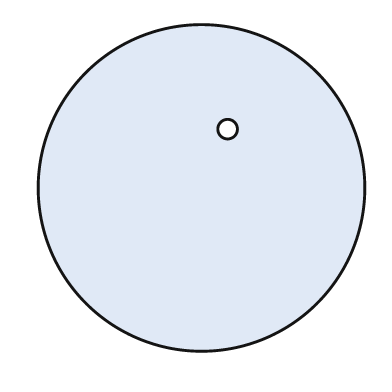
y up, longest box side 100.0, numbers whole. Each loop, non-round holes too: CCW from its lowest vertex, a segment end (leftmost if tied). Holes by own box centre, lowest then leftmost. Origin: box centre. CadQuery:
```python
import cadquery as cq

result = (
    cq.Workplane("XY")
    .moveTo(0.0, 0.0)
    .circle(50.0)
    .moveTo(8.0, 18.0)
    .circle(3.0)
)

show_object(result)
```